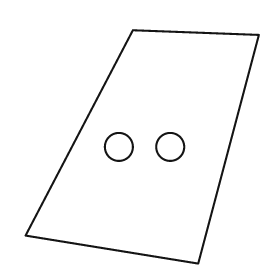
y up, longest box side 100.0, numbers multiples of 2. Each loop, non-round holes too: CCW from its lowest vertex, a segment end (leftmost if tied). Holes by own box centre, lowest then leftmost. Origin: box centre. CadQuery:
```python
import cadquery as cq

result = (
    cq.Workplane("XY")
    .moveTo(24.0, -50.0)
    .lineTo(50.0, 48.0)
    .lineTo(-4.0, 50.0)
    .lineTo(-50.0, -38.0)
    .close()
    .moveTo(-10.0, 0.0)
    .circle(6.0)
    .moveTo(12.0, 0.0)
    .circle(6.0)
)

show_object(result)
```